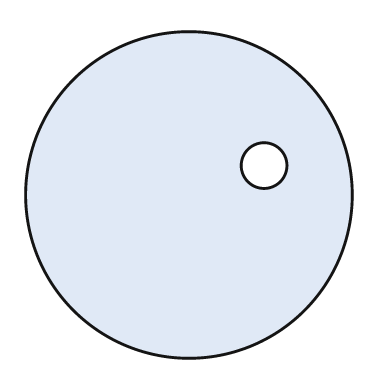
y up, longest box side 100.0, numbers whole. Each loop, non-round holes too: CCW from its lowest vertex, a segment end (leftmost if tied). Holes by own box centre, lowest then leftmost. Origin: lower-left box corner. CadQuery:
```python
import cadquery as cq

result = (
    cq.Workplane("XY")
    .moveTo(50.0, 50.0)
    .circle(50.0)
    .moveTo(73.0, 59.0)
    .circle(7.0)
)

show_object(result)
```